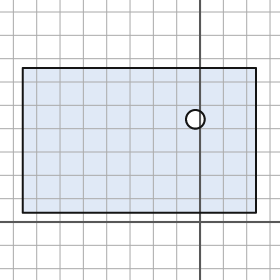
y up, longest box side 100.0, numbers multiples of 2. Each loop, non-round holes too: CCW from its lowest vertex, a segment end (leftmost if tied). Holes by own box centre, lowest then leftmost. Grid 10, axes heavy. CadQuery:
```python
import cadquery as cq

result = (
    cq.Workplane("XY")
    .moveTo(-76.0, 4.0)
    .lineTo(24.0, 4.0)
    .lineTo(24.0, 66.0)
    .lineTo(-76.0, 66.0)
    .close()
    .moveTo(-2.0, 44.0)
    .circle(4.0)
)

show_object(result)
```